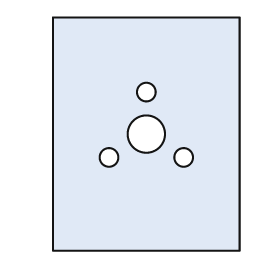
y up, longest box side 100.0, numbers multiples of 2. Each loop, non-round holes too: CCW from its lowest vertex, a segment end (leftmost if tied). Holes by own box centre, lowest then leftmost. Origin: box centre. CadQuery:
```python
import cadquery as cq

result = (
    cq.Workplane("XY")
    .moveTo(-40.0, -50.0)
    .lineTo(40.0, -50.0)
    .lineTo(40.0, 50.0)
    .lineTo(-40.0, 50.0)
    .close()
    .moveTo(-16.0, -10.0)
    .circle(4.0)
    .moveTo(16.0, -10.0)
    .circle(4.0)
    .moveTo(0.0, 0.0)
    .circle(8.0)
    .moveTo(0.0, 18.0)
    .circle(4.0)
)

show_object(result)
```